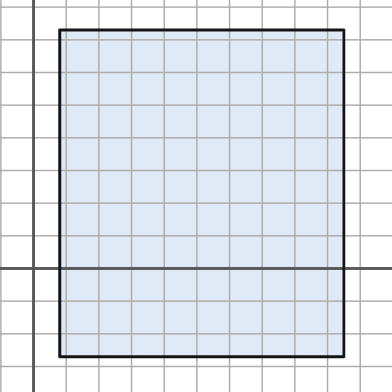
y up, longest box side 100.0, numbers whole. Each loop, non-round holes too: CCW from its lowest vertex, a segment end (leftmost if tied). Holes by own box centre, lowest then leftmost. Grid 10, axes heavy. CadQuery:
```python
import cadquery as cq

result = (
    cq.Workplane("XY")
    .moveTo(8.0, -27.0)
    .lineTo(95.0, -27.0)
    .lineTo(95.0, 73.0)
    .lineTo(8.0, 73.0)
    .close()
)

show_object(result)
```